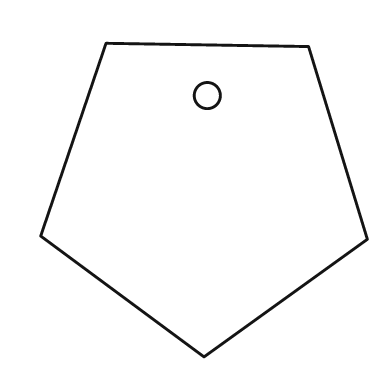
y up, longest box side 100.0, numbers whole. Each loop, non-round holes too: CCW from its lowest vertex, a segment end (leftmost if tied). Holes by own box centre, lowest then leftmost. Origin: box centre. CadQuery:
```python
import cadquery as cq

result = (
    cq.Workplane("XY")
    .moveTo(0.0, -48.0)
    .lineTo(50.0, -12.0)
    .lineTo(32.0, 47.0)
    .lineTo(-30.0, 48.0)
    .lineTo(-50.0, -11.0)
    .close()
    .moveTo(1.0, 32.0)
    .circle(4.0)
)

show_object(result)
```